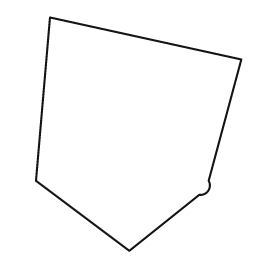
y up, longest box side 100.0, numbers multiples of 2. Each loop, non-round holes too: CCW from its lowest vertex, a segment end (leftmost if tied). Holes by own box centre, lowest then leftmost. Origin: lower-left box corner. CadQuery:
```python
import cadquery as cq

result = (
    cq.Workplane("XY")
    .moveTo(40.0, 0.0)
    .lineTo(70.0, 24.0)
    .threePointArc((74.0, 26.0), (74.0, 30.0))
    .lineTo(88.0, 82.0)
    .lineTo(6.0, 100.0)
    .lineTo(0.0, 30.0)
    .close()
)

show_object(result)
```